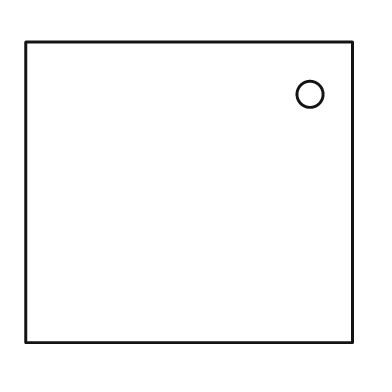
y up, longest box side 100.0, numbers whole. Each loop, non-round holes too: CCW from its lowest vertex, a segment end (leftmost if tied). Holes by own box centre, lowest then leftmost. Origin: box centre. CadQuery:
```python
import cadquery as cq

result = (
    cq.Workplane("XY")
    .moveTo(-50.0, -46.0)
    .lineTo(50.0, -46.0)
    .lineTo(50.0, 46.0)
    .lineTo(-50.0, 46.0)
    .close()
    .moveTo(37.0, 30.0)
    .circle(4.0)
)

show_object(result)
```